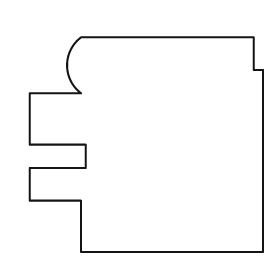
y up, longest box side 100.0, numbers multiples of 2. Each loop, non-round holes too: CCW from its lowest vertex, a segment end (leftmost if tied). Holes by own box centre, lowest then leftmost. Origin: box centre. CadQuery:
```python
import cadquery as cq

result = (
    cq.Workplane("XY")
    .moveTo(-28.0, -46.0)
    .lineTo(50.0, -46.0)
    .lineTo(50.0, 32.0)
    .lineTo(46.0, 32.0)
    .lineTo(46.0, 46.0)
    .lineTo(-28.0, 46.0)
    .threePointArc((-34.0, 34.0), (-28.0, 22.0))
    .lineTo(-50.0, 22.0)
    .lineTo(-50.0, 0.0)
    .lineTo(-26.0, 0.0)
    .lineTo(-26.0, -10.0)
    .lineTo(-50.0, -10.0)
    .lineTo(-50.0, -24.0)
    .lineTo(-28.0, -24.0)
    .close()
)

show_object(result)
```